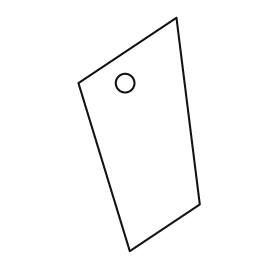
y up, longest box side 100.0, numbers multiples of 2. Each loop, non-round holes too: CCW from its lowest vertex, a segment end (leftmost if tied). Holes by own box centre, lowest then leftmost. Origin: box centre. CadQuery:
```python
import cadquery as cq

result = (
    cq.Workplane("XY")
    .moveTo(-4.0, -50.0)
    .lineTo(26.0, -30.0)
    .lineTo(16.0, 50.0)
    .lineTo(-26.0, 22.0)
    .close()
    .moveTo(-6.0, 22.0)
    .circle(4.0)
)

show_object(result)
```